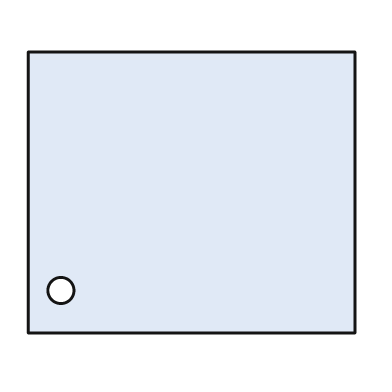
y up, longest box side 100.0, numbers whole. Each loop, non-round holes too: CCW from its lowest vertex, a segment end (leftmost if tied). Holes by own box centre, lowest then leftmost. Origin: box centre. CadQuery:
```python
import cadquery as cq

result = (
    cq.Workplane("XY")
    .moveTo(-50.0, -43.0)
    .lineTo(50.0, -43.0)
    .lineTo(50.0, 43.0)
    .lineTo(-50.0, 43.0)
    .close()
    .moveTo(-40.0, -30.0)
    .circle(4.0)
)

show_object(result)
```